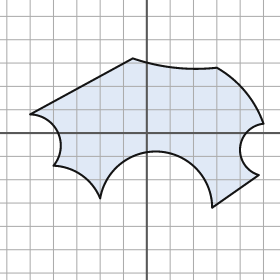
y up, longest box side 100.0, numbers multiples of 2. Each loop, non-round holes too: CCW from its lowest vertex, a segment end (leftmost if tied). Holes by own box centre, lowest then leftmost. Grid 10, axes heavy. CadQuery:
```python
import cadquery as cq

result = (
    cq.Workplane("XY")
    .moveTo(28.0, -32.0)
    .lineTo(48.0, -18.0)
    .threePointArc((40.0, -6.0), (50.0, 4.0))
    .threePointArc((42.0, 18.0), (30.0, 28.0))
    .threePointArc((12.0, 28.0), (-6.0, 32.0))
    .lineTo(-50.0, 8.0)
    .threePointArc((-38.0, 0.0), (-40.0, -14.0))
    .threePointArc((-28.0, -18.0), (-20.0, -28.0))
    .threePointArc((6.0, -8.0), (28.0, -32.0))
    .close()
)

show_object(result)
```